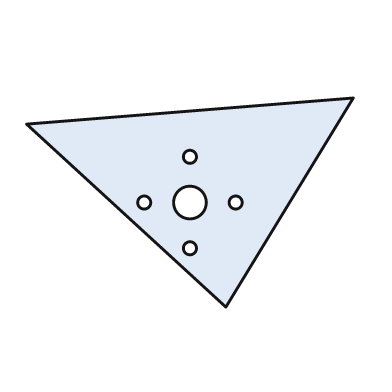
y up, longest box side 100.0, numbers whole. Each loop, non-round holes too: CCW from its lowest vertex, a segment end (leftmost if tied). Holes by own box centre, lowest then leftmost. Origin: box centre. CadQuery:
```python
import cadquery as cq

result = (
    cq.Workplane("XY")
    .moveTo(11.0, -32.0)
    .lineTo(50.0, 32.0)
    .lineTo(-50.0, 24.0)
    .close()
    .moveTo(0.0, -14.0)
    .circle(2.0)
    .moveTo(-14.0, 0.0)
    .circle(2.0)
    .moveTo(0.0, 0.0)
    .circle(5.0)
    .moveTo(14.0, 0.0)
    .circle(2.0)
    .moveTo(0.0, 14.0)
    .circle(2.0)
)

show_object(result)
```